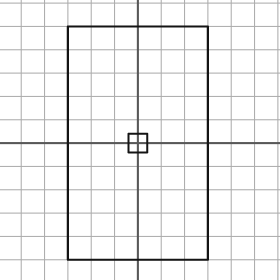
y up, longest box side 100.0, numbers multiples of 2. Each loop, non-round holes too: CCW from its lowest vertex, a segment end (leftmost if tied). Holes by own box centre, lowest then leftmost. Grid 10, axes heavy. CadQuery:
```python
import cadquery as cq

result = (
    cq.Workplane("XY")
    .moveTo(-30.0, -50.0)
    .lineTo(30.0, -50.0)
    .lineTo(30.0, 50.0)
    .lineTo(-30.0, 50.0)
    .close()
    .moveTo(-4.0, -4.0)
    .lineTo(4.0, -4.0)
    .lineTo(4.0, 4.0)
    .lineTo(-4.0, 4.0)
    .close()
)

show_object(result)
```